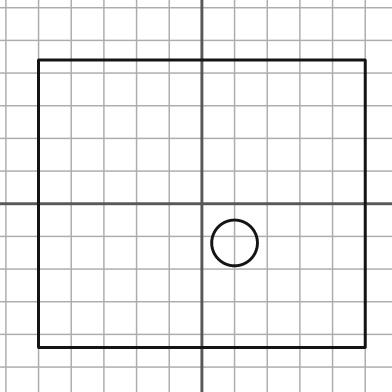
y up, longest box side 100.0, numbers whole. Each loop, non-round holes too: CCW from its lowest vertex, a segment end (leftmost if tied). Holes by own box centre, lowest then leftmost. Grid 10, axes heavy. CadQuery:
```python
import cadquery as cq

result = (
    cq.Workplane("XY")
    .moveTo(-50.0, -44.0)
    .lineTo(50.0, -44.0)
    .lineTo(50.0, 44.0)
    .lineTo(-50.0, 44.0)
    .close()
    .moveTo(10.0, -12.0)
    .circle(7.0)
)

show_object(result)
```